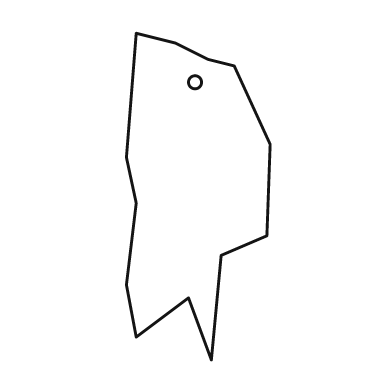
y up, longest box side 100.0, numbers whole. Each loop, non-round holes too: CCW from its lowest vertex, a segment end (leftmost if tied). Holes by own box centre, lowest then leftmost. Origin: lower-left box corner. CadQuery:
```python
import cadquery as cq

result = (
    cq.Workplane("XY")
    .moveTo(26.0, 0.0)
    .lineTo(29.0, 32.0)
    .lineTo(43.0, 38.0)
    .lineTo(44.0, 66.0)
    .lineTo(33.0, 90.0)
    .lineTo(25.0, 92.0)
    .lineTo(15.0, 97.0)
    .lineTo(3.0, 100.0)
    .lineTo(0.0, 62.0)
    .lineTo(3.0, 48.0)
    .lineTo(0.0, 23.0)
    .lineTo(3.0, 7.0)
    .lineTo(19.0, 19.0)
    .close()
    .moveTo(21.0, 85.0)
    .circle(2.0)
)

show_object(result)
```